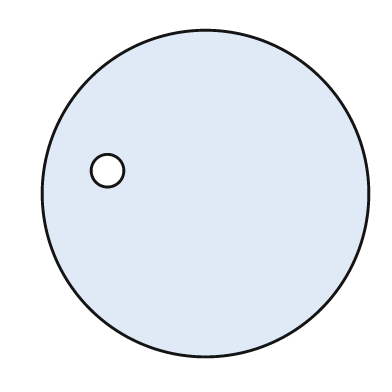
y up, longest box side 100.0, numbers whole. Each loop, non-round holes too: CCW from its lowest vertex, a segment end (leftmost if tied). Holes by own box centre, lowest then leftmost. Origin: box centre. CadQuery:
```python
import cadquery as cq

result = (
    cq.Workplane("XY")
    .moveTo(0.0, 0.0)
    .circle(50.0)
    .moveTo(-30.0, 7.0)
    .circle(5.0)
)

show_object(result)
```